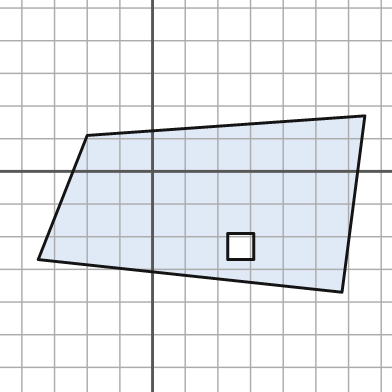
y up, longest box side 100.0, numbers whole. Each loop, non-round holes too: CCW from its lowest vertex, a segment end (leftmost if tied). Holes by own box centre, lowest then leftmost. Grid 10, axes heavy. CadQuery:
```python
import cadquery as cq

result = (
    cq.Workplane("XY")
    .moveTo(58.0, -37.0)
    .lineTo(65.0, 17.0)
    .lineTo(-20.0, 11.0)
    .lineTo(-35.0, -27.0)
    .close()
    .moveTo(23.0, -27.0)
    .lineTo(31.0, -27.0)
    .lineTo(31.0, -19.0)
    .lineTo(23.0, -19.0)
    .close()
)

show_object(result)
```